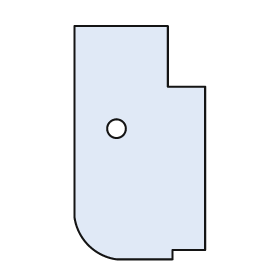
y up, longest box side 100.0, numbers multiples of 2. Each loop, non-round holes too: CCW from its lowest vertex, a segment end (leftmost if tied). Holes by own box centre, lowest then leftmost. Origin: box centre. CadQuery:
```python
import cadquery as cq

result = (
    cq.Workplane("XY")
    .moveTo(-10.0, -50.0)
    .lineTo(14.0, -50.0)
    .lineTo(14.0, -46.0)
    .lineTo(28.0, -46.0)
    .lineTo(28.0, 24.0)
    .lineTo(12.0, 24.0)
    .lineTo(12.0, 50.0)
    .lineTo(-28.0, 50.0)
    .lineTo(-28.0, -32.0)
    .threePointArc((-22.0, -44.0), (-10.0, -50.0))
    .close()
    .moveTo(-10.0, 6.0)
    .circle(4.0)
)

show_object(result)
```